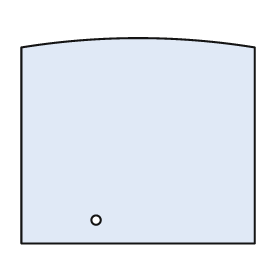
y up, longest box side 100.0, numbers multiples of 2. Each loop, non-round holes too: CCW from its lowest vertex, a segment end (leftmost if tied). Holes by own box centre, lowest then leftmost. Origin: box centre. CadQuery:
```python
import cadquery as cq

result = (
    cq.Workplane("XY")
    .moveTo(-50.0, -44.0)
    .lineTo(50.0, -44.0)
    .lineTo(50.0, 40.0)
    .threePointArc((0.0, 44.0), (-50.0, 40.0))
    .close()
    .moveTo(-18.0, -34.0)
    .circle(2.0)
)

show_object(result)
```